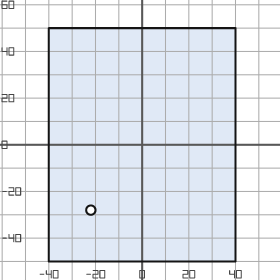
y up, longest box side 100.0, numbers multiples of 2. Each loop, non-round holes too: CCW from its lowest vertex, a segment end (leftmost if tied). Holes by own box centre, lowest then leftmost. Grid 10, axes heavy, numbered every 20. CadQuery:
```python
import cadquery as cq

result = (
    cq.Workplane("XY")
    .moveTo(-40.0, -50.0)
    .lineTo(40.0, -50.0)
    .lineTo(40.0, 50.0)
    .lineTo(-40.0, 50.0)
    .close()
    .moveTo(-22.0, -28.0)
    .circle(2.0)
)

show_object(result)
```